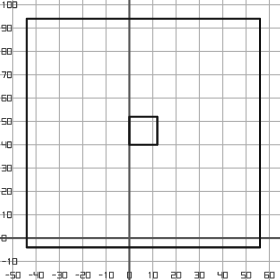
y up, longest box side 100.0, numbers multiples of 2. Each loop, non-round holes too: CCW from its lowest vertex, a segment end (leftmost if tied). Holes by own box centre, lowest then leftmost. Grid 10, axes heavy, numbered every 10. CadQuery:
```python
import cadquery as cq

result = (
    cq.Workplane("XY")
    .moveTo(-44.0, -4.0)
    .lineTo(56.0, -4.0)
    .lineTo(56.0, 94.0)
    .lineTo(-44.0, 94.0)
    .close()
    .moveTo(0.0, 40.0)
    .lineTo(12.0, 40.0)
    .lineTo(12.0, 52.0)
    .lineTo(0.0, 52.0)
    .close()
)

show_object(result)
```